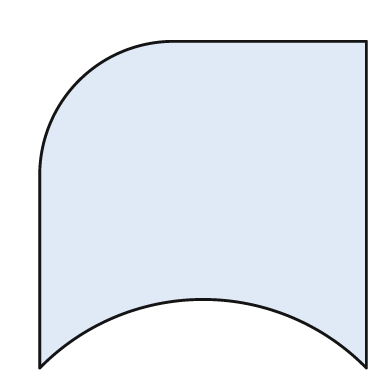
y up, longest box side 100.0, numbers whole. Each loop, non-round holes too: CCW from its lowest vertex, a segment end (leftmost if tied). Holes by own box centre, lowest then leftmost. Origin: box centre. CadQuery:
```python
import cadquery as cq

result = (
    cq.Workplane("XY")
    .moveTo(-50.0, -50.0)
    .threePointArc((0.0, -29.0), (50.0, -50.0))
    .lineTo(50.0, 50.0)
    .lineTo(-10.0, 50.0)
    .threePointArc((-38.0, 38.0), (-50.0, 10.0))
    .close()
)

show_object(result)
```